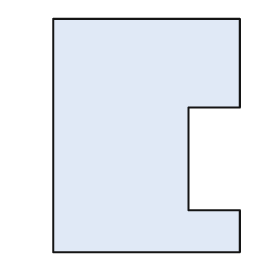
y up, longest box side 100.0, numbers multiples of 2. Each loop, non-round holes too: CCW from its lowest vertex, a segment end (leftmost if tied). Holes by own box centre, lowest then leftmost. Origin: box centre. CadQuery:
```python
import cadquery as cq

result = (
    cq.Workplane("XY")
    .moveTo(-40.0, -50.0)
    .lineTo(40.0, -50.0)
    .lineTo(40.0, -32.0)
    .lineTo(18.0, -32.0)
    .lineTo(18.0, 12.0)
    .lineTo(40.0, 12.0)
    .lineTo(40.0, 50.0)
    .lineTo(-40.0, 50.0)
    .close()
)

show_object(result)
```